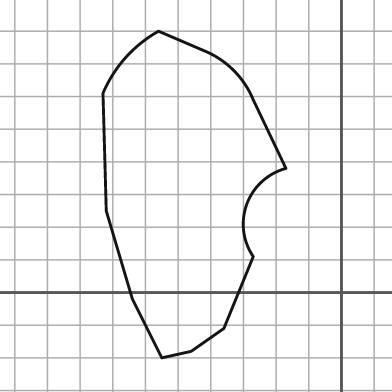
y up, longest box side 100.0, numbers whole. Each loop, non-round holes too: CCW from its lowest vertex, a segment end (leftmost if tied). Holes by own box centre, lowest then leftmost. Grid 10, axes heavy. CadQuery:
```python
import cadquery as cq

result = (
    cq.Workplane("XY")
    .moveTo(-55.0, -20.0)
    .lineTo(-46.0, -18.0)
    .lineTo(-36.0, -11.0)
    .lineTo(-27.0, 11.0)
    .threePointArc((-29.0, 27.0), (-17.0, 38.0))
    .lineTo(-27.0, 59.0)
    .threePointArc((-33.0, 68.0), (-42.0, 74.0))
    .lineTo(-56.0, 80.0)
    .threePointArc((-66.0, 72.0), (-73.0, 61.0))
    .lineTo(-72.0, 25.0)
    .lineTo(-64.0, -2.0)
    .close()
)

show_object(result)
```